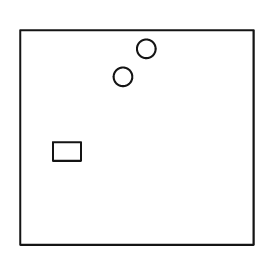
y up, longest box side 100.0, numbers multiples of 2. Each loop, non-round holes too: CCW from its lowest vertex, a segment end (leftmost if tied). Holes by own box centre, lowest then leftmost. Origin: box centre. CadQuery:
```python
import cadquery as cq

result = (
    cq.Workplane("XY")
    .moveTo(-50.0, -46.0)
    .lineTo(50.0, -46.0)
    .lineTo(50.0, 46.0)
    .lineTo(-50.0, 46.0)
    .close()
    .moveTo(-36.0, -10.0)
    .lineTo(-24.0, -10.0)
    .lineTo(-24.0, -2.0)
    .lineTo(-36.0, -2.0)
    .close()
    .moveTo(-6.0, 26.0)
    .circle(4.0)
    .moveTo(4.0, 38.0)
    .circle(4.0)
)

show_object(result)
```